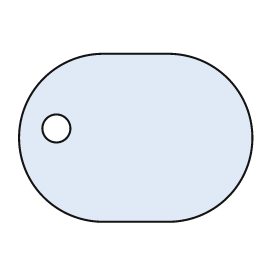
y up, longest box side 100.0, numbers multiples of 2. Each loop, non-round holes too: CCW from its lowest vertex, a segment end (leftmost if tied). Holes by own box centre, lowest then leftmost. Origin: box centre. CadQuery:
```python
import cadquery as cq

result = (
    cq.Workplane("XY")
    .moveTo(-14.0, -36.0)
    .lineTo(14.0, -36.0)
    .threePointArc((50.0, 0.0), (14.0, 36.0))
    .lineTo(-14.0, 36.0)
    .threePointArc((-50.0, 0.0), (-14.0, -36.0))
    .close()
    .moveTo(-34.0, 4.0)
    .circle(6.0)
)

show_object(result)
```